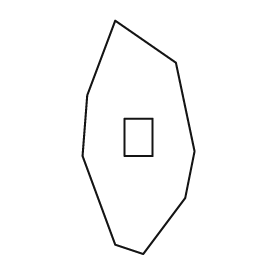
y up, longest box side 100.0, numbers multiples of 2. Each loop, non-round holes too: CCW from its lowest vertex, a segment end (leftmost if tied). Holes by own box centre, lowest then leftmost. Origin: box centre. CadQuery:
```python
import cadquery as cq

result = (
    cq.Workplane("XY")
    .moveTo(2.0, -50.0)
    .lineTo(20.0, -26.0)
    .lineTo(24.0, -6.0)
    .lineTo(16.0, 32.0)
    .lineTo(-10.0, 50.0)
    .lineTo(-22.0, 18.0)
    .lineTo(-24.0, -8.0)
    .lineTo(-10.0, -46.0)
    .close()
    .moveTo(-6.0, -8.0)
    .lineTo(6.0, -8.0)
    .lineTo(6.0, 8.0)
    .lineTo(-6.0, 8.0)
    .close()
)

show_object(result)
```